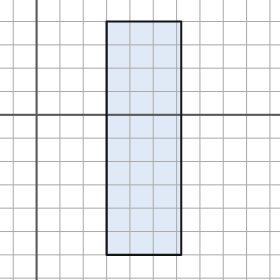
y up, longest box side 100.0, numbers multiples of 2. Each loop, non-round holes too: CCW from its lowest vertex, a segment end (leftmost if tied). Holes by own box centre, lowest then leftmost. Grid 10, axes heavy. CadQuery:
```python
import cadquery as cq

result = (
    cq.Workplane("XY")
    .moveTo(30.0, -60.0)
    .lineTo(62.0, -60.0)
    .lineTo(62.0, 40.0)
    .lineTo(30.0, 40.0)
    .close()
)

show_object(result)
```